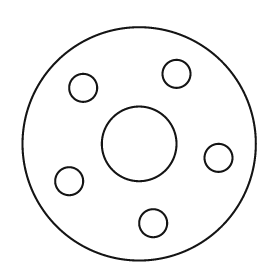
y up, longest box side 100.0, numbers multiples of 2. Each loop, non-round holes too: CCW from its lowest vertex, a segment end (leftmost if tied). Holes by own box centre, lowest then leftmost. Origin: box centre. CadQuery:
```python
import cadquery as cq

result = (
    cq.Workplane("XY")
    .moveTo(0.0, 0.0)
    .circle(50.0)
    .moveTo(6.0, -34.0)
    .circle(6.0)
    .moveTo(-30.0, -16.0)
    .circle(6.0)
    .moveTo(34.0, -6.0)
    .circle(6.0)
    .moveTo(0.0, 0.0)
    .circle(16.0)
    .moveTo(-24.0, 24.0)
    .circle(6.0)
    .moveTo(16.0, 30.0)
    .circle(6.0)
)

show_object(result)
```